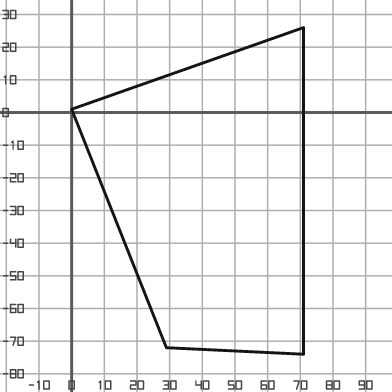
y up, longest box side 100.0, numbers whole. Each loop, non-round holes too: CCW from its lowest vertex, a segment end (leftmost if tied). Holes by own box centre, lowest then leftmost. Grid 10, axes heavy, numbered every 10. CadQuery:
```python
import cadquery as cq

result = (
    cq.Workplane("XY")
    .moveTo(71.0, -74.0)
    .lineTo(71.0, 26.0)
    .lineTo(0.0, 1.0)
    .lineTo(29.0, -72.0)
    .close()
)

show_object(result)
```